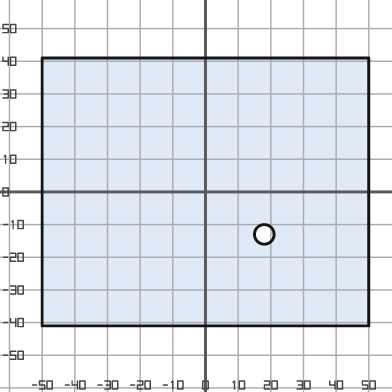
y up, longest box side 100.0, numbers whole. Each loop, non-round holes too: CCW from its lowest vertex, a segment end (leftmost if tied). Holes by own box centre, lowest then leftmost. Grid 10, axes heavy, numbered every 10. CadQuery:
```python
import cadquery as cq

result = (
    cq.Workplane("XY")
    .moveTo(-50.0, -41.0)
    .lineTo(50.0, -41.0)
    .lineTo(50.0, 41.0)
    .lineTo(-50.0, 41.0)
    .close()
    .moveTo(18.0, -13.0)
    .circle(3.0)
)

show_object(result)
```